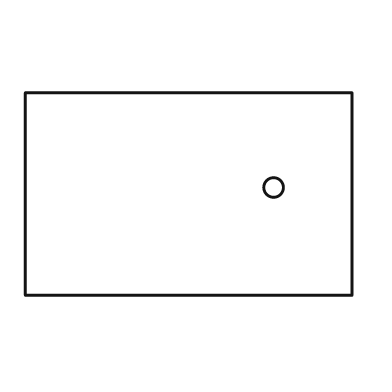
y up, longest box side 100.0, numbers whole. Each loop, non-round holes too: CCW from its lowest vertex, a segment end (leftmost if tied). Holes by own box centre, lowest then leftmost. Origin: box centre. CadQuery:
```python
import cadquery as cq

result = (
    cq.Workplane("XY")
    .moveTo(-50.0, -31.0)
    .lineTo(50.0, -31.0)
    .lineTo(50.0, 31.0)
    .lineTo(-50.0, 31.0)
    .close()
    .moveTo(26.0, 2.0)
    .circle(3.0)
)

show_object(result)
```